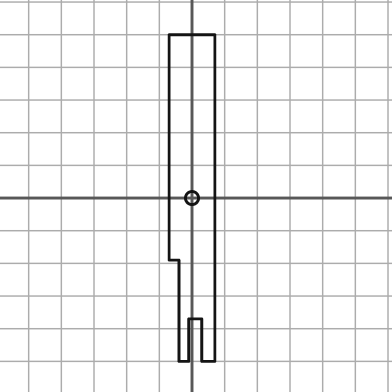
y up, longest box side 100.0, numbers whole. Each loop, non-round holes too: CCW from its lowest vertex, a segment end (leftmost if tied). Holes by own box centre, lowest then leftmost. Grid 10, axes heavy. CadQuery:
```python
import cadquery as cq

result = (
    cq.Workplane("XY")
    .moveTo(-4.0, -50.0)
    .lineTo(-1.0, -50.0)
    .lineTo(-1.0, -37.0)
    .lineTo(3.0, -37.0)
    .lineTo(3.0, -50.0)
    .lineTo(7.0, -50.0)
    .lineTo(7.0, 50.0)
    .lineTo(-7.0, 50.0)
    .lineTo(-7.0, -19.0)
    .lineTo(-4.0, -19.0)
    .close()
    .moveTo(0.0, 0.0)
    .circle(2.0)
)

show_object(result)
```